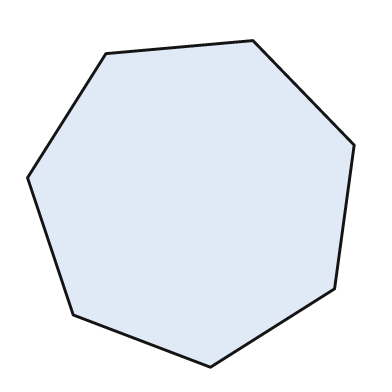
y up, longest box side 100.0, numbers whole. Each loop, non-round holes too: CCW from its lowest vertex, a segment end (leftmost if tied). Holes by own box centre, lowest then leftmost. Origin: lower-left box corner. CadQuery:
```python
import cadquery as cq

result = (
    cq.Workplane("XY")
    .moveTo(56.0, 0.0)
    .lineTo(94.0, 24.0)
    .lineTo(100.0, 68.0)
    .lineTo(69.0, 100.0)
    .lineTo(24.0, 96.0)
    .lineTo(0.0, 58.0)
    .lineTo(14.0, 16.0)
    .close()
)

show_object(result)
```